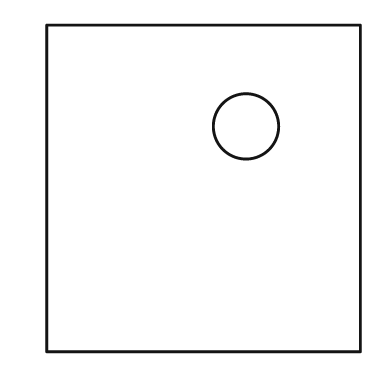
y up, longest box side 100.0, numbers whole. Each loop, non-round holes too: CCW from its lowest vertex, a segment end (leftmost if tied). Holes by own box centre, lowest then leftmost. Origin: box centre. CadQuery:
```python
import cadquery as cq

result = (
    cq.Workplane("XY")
    .moveTo(-48.0, -50.0)
    .lineTo(48.0, -50.0)
    .lineTo(48.0, 50.0)
    .lineTo(-48.0, 50.0)
    .close()
    .moveTo(13.0, 19.0)
    .circle(10.0)
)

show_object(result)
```